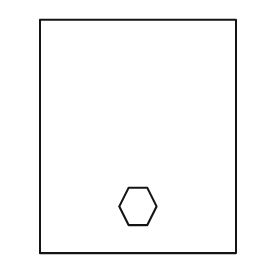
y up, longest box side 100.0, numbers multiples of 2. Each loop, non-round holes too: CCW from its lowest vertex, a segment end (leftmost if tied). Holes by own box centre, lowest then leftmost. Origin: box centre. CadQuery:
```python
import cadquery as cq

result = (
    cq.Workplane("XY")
    .moveTo(-42.0, -50.0)
    .lineTo(42.0, -50.0)
    .lineTo(42.0, 50.0)
    .lineTo(-42.0, 50.0)
    .close()
    .moveTo(-4.0, -38.0)
    .lineTo(4.0, -38.0)
    .lineTo(8.0, -30.0)
    .lineTo(4.0, -22.0)
    .lineTo(-4.0, -22.0)
    .lineTo(-8.0, -30.0)
    .close()
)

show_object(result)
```